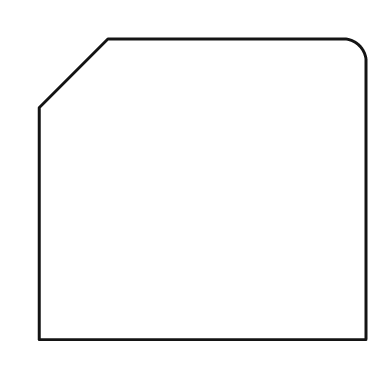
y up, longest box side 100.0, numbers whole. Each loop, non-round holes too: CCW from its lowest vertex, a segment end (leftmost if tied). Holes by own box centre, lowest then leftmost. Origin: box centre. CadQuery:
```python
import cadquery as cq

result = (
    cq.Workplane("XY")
    .moveTo(-50.0, -46.0)
    .lineTo(50.0, -46.0)
    .lineTo(50.0, 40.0)
    .threePointArc((48.0, 44.0), (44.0, 46.0))
    .lineTo(-29.0, 46.0)
    .lineTo(-50.0, 25.0)
    .close()
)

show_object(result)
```